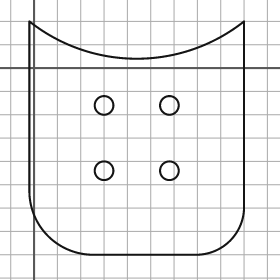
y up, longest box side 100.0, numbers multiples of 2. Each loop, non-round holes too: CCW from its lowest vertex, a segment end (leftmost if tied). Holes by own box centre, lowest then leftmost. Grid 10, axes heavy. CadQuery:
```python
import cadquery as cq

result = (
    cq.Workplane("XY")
    .moveTo(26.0, -80.0)
    .lineTo(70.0, -80.0)
    .threePointArc((84.0, -74.0), (90.0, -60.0))
    .lineTo(90.0, 20.0)
    .threePointArc((44.0, 4.0), (-2.0, 20.0))
    .lineTo(-2.0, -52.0)
    .threePointArc((6.0, -72.0), (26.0, -80.0))
    .close()
    .moveTo(30.0, -44.0)
    .circle(4.0)
    .moveTo(58.0, -44.0)
    .circle(4.0)
    .moveTo(30.0, -16.0)
    .circle(4.0)
    .moveTo(58.0, -16.0)
    .circle(4.0)
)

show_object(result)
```